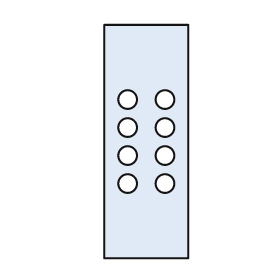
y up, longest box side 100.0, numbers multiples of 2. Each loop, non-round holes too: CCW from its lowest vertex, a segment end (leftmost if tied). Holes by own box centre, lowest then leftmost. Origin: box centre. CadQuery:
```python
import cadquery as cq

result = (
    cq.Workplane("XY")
    .moveTo(-18.0, -50.0)
    .lineTo(18.0, -50.0)
    .lineTo(18.0, 50.0)
    .lineTo(-18.0, 50.0)
    .close()
    .moveTo(-8.0, -18.0)
    .circle(4.0)
    .moveTo(8.0, -18.0)
    .circle(4.0)
    .moveTo(-8.0, -6.0)
    .circle(4.0)
    .moveTo(8.0, -6.0)
    .circle(4.0)
    .moveTo(-8.0, 6.0)
    .circle(4.0)
    .moveTo(8.0, 6.0)
    .circle(4.0)
    .moveTo(-8.0, 18.0)
    .circle(4.0)
    .moveTo(8.0, 18.0)
    .circle(4.0)
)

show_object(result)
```